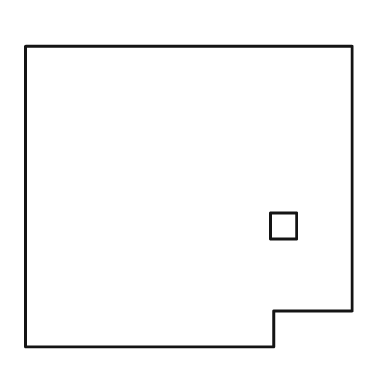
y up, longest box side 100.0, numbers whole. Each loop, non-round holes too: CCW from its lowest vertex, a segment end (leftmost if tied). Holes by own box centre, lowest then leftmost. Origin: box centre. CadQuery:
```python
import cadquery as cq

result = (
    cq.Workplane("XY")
    .moveTo(-50.0, -46.0)
    .lineTo(26.0, -46.0)
    .lineTo(26.0, -35.0)
    .lineTo(50.0, -35.0)
    .lineTo(50.0, 46.0)
    .lineTo(-50.0, 46.0)
    .close()
    .moveTo(25.0, -13.0)
    .lineTo(33.0, -13.0)
    .lineTo(33.0, -5.0)
    .lineTo(25.0, -5.0)
    .close()
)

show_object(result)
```